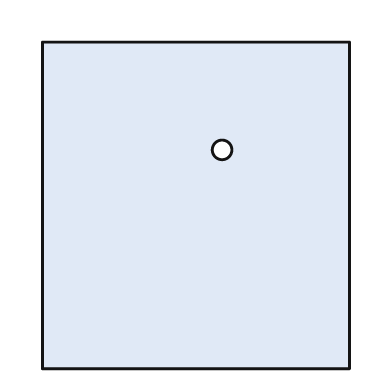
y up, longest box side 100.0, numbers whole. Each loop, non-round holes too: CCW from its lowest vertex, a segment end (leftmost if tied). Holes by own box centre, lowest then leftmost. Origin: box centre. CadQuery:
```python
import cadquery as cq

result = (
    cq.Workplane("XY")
    .moveTo(-47.0, -50.0)
    .lineTo(47.0, -50.0)
    .lineTo(47.0, 50.0)
    .lineTo(-47.0, 50.0)
    .close()
    .moveTo(8.0, 17.0)
    .circle(3.0)
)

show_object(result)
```